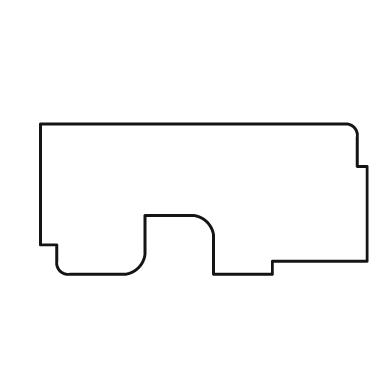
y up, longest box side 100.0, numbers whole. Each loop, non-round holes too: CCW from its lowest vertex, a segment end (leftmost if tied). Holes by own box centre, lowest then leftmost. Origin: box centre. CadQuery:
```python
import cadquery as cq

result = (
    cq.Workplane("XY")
    .moveTo(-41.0, -23.0)
    .lineTo(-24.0, -23.0)
    .threePointArc((-20.0, -21.0), (-18.0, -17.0))
    .lineTo(-18.0, -5.0)
    .lineTo(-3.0, -5.0)
    .threePointArc((1.0, -7.0), (3.0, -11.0))
    .lineTo(3.0, -23.0)
    .lineTo(21.0, -23.0)
    .lineTo(21.0, -19.0)
    .lineTo(50.0, -19.0)
    .lineTo(50.0, 10.0)
    .lineTo(47.0, 10.0)
    .lineTo(47.0, 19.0)
    .threePointArc((46.0, 22.0), (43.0, 23.0))
    .lineTo(-50.0, 23.0)
    .lineTo(-50.0, -14.0)
    .lineTo(-45.0, -14.0)
    .lineTo(-45.0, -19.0)
    .threePointArc((-44.0, -22.0), (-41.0, -23.0))
    .close()
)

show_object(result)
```